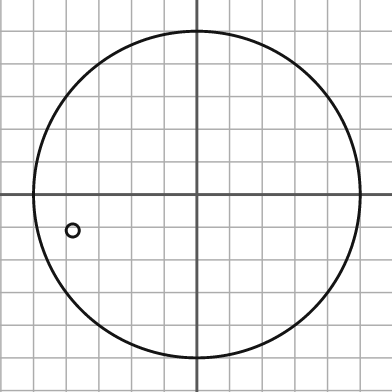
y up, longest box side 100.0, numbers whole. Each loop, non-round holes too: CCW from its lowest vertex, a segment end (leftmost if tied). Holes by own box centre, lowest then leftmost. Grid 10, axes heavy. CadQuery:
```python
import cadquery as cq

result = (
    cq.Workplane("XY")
    .moveTo(0.0, 0.0)
    .circle(50.0)
    .moveTo(-38.0, -11.0)
    .circle(2.0)
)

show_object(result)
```